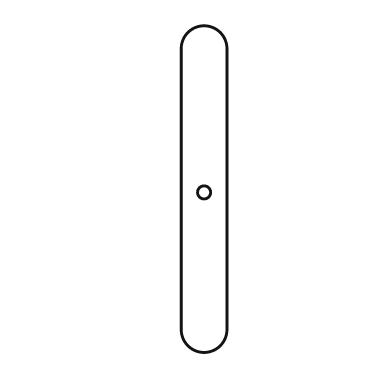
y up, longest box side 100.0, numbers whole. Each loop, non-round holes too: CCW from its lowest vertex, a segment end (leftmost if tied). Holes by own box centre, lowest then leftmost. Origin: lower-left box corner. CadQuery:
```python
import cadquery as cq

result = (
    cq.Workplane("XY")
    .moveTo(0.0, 7.0)
    .threePointArc((7.0, 0.0), (14.0, 7.0))
    .lineTo(14.0, 93.0)
    .threePointArc((7.0, 100.0), (0.0, 93.0))
    .close()
    .moveTo(7.0, 49.0)
    .circle(2.0)
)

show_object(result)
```